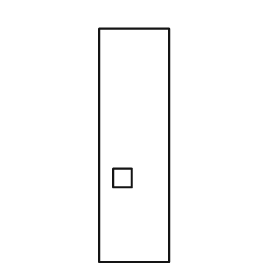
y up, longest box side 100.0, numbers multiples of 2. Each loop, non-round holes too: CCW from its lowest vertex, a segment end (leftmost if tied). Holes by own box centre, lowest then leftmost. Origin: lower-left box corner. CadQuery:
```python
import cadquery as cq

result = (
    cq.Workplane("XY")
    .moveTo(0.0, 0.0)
    .lineTo(30.0, 0.0)
    .lineTo(30.0, 100.0)
    .lineTo(0.0, 100.0)
    .close()
    .moveTo(6.0, 32.0)
    .lineTo(14.0, 32.0)
    .lineTo(14.0, 40.0)
    .lineTo(6.0, 40.0)
    .close()
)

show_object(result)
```